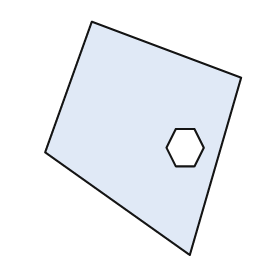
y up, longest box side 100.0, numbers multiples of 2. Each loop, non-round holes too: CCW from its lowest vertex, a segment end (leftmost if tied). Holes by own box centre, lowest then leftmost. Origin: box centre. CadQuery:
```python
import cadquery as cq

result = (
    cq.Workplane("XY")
    .moveTo(20.0, -50.0)
    .lineTo(42.0, 26.0)
    .lineTo(-22.0, 50.0)
    .lineTo(-42.0, -6.0)
    .close()
    .moveTo(14.0, -12.0)
    .lineTo(22.0, -12.0)
    .lineTo(26.0, -4.0)
    .lineTo(22.0, 4.0)
    .lineTo(14.0, 4.0)
    .lineTo(10.0, -4.0)
    .close()
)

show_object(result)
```